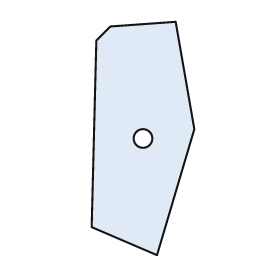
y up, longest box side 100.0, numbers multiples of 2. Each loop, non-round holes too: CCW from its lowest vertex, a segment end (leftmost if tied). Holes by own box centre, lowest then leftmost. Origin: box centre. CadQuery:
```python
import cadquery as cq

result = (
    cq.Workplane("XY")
    .moveTo(6.0, -50.0)
    .lineTo(22.0, 4.0)
    .lineTo(14.0, 50.0)
    .lineTo(-14.0, 48.0)
    .lineTo(-20.0, 42.0)
    .lineTo(-22.0, -38.0)
    .close()
    .moveTo(0.0, 0.0)
    .circle(4.0)
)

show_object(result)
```